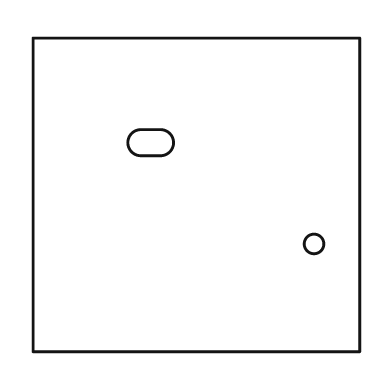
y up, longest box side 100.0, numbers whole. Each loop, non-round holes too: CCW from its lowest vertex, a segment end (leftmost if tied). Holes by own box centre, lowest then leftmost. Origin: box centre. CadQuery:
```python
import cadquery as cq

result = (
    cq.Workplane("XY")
    .moveTo(-50.0, -48.0)
    .lineTo(50.0, -48.0)
    .lineTo(50.0, 48.0)
    .lineTo(-50.0, 48.0)
    .close()
    .moveTo(36.0, -15.0)
    .circle(3.0)
    .moveTo(-17.0, 12.0)
    .lineTo(-11.0, 12.0)
    .threePointArc((-7.0, 16.0), (-11.0, 20.0))
    .lineTo(-17.0, 20.0)
    .threePointArc((-21.0, 16.0), (-17.0, 12.0))
    .close()
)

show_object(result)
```